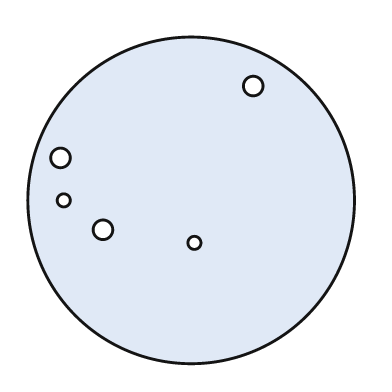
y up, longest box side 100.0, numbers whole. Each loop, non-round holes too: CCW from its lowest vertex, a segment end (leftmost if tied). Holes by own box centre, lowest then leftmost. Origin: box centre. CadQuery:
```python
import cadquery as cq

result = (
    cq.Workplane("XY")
    .moveTo(0.0, 0.0)
    .circle(50.0)
    .moveTo(1.0, -13.0)
    .circle(2.0)
    .moveTo(-27.0, -9.0)
    .circle(3.0)
    .moveTo(-39.0, 0.0)
    .circle(2.0)
    .moveTo(-40.0, 13.0)
    .circle(3.0)
    .moveTo(19.0, 35.0)
    .circle(3.0)
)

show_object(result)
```